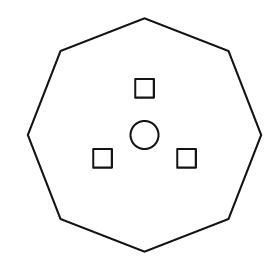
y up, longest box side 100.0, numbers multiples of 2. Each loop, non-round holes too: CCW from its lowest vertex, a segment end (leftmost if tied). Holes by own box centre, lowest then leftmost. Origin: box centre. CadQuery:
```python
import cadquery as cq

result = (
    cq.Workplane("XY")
    .moveTo(0.0, -50.0)
    .lineTo(36.0, -36.0)
    .lineTo(50.0, 0.0)
    .lineTo(36.0, 36.0)
    .lineTo(0.0, 50.0)
    .lineTo(-36.0, 36.0)
    .lineTo(-50.0, 0.0)
    .lineTo(-36.0, -36.0)
    .close()
    .moveTo(-22.0, -14.0)
    .lineTo(-14.0, -14.0)
    .lineTo(-14.0, -6.0)
    .lineTo(-22.0, -6.0)
    .close()
    .moveTo(14.0, -14.0)
    .lineTo(22.0, -14.0)
    .lineTo(22.0, -6.0)
    .lineTo(14.0, -6.0)
    .close()
    .moveTo(0.0, 0.0)
    .circle(6.0)
    .moveTo(-4.0, 16.0)
    .lineTo(4.0, 16.0)
    .lineTo(4.0, 24.0)
    .lineTo(-4.0, 24.0)
    .close()
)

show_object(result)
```